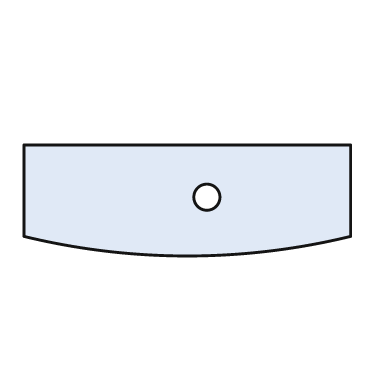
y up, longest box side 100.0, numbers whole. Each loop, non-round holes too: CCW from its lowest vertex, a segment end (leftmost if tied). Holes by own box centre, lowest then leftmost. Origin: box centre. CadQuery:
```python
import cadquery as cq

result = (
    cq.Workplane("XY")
    .moveTo(-50.0, -11.0)
    .threePointArc((0.0, -17.0), (50.0, -11.0))
    .lineTo(50.0, 17.0)
    .lineTo(-50.0, 17.0)
    .close()
    .moveTo(6.0, 1.0)
    .circle(4.0)
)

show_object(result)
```